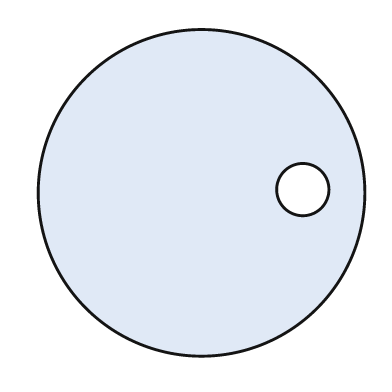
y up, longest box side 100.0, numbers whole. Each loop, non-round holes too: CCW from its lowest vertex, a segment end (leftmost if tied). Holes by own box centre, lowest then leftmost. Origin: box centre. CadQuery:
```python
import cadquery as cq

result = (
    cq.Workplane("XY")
    .moveTo(0.0, 0.0)
    .circle(50.0)
    .moveTo(31.0, 1.0)
    .circle(8.0)
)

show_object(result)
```